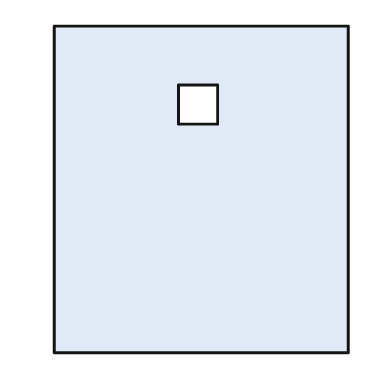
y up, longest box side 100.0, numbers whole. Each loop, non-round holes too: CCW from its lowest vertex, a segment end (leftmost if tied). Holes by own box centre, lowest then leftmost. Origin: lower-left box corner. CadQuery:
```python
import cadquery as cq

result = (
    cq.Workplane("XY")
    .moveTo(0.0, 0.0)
    .lineTo(90.0, 0.0)
    .lineTo(90.0, 100.0)
    .lineTo(0.0, 100.0)
    .close()
    .moveTo(38.0, 70.0)
    .lineTo(50.0, 70.0)
    .lineTo(50.0, 82.0)
    .lineTo(38.0, 82.0)
    .close()
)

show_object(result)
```